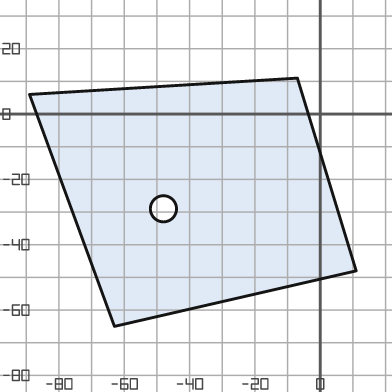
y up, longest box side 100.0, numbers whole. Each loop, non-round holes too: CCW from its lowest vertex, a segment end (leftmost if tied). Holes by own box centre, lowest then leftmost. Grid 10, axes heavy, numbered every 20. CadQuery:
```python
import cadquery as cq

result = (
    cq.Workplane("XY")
    .moveTo(-63.0, -65.0)
    .lineTo(11.0, -48.0)
    .lineTo(-7.0, 11.0)
    .lineTo(-89.0, 6.0)
    .close()
    .moveTo(-48.0, -29.0)
    .circle(4.0)
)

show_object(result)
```